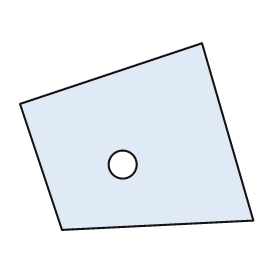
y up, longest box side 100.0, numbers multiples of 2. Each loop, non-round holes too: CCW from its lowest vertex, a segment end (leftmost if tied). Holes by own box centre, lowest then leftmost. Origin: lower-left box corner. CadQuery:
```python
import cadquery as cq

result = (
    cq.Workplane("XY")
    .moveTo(18.0, 0.0)
    .lineTo(100.0, 4.0)
    .lineTo(78.0, 80.0)
    .lineTo(0.0, 54.0)
    .close()
    .moveTo(44.0, 28.0)
    .circle(6.0)
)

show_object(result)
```